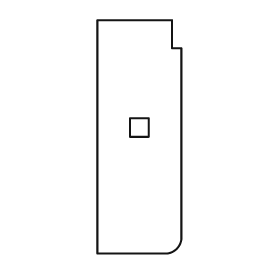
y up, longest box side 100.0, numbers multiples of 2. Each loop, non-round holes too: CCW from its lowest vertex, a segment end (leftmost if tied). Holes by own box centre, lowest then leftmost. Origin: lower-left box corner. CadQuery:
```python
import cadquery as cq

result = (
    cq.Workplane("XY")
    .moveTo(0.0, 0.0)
    .lineTo(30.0, 0.0)
    .threePointArc((34.0, 2.0), (36.0, 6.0))
    .lineTo(36.0, 88.0)
    .lineTo(32.0, 88.0)
    .lineTo(32.0, 100.0)
    .lineTo(0.0, 100.0)
    .close()
    .moveTo(14.0, 50.0)
    .lineTo(22.0, 50.0)
    .lineTo(22.0, 58.0)
    .lineTo(14.0, 58.0)
    .close()
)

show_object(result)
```